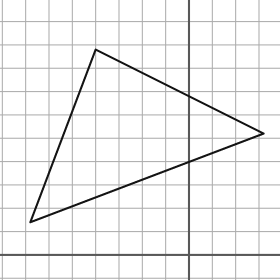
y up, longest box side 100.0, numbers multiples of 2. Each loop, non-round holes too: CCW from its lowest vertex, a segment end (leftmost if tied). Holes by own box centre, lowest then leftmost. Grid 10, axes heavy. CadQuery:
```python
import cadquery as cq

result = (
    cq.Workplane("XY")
    .moveTo(-68.0, 14.0)
    .lineTo(32.0, 52.0)
    .lineTo(-40.0, 88.0)
    .close()
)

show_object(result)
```